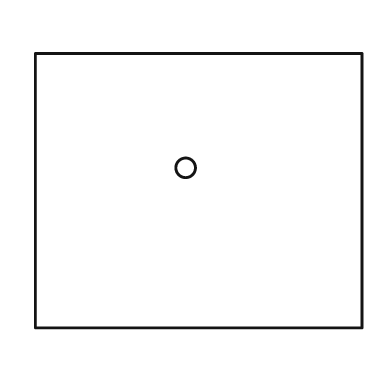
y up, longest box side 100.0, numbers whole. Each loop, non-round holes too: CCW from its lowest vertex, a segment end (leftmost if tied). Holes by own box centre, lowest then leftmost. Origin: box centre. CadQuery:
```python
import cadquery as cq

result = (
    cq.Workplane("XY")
    .moveTo(-50.0, -42.0)
    .lineTo(50.0, -42.0)
    .lineTo(50.0, 42.0)
    .lineTo(-50.0, 42.0)
    .close()
    .moveTo(-4.0, 7.0)
    .circle(3.0)
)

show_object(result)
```